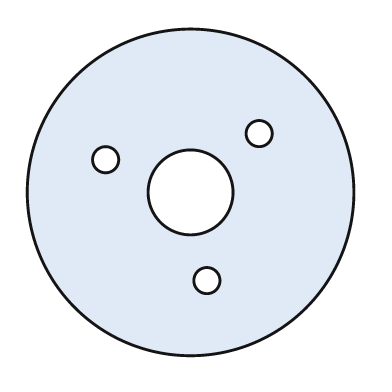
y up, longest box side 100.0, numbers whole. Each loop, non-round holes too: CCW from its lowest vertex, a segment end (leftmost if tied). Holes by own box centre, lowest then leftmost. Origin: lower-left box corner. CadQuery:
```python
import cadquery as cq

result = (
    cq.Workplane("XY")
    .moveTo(50.0, 50.0)
    .circle(50.0)
    .moveTo(55.0, 23.0)
    .circle(4.0)
    .moveTo(50.0, 50.0)
    .circle(13.0)
    .moveTo(24.0, 60.0)
    .circle(4.0)
    .moveTo(71.0, 68.0)
    .circle(4.0)
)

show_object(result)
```